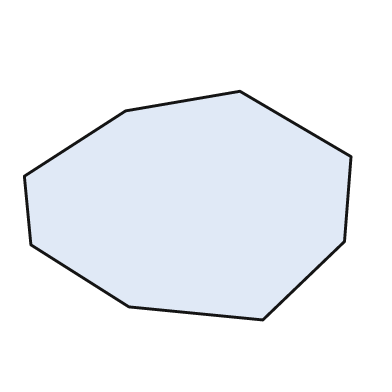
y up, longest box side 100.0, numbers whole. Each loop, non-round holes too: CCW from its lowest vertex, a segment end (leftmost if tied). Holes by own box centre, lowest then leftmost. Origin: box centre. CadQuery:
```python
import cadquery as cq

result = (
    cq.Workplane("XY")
    .moveTo(23.0, -35.0)
    .lineTo(48.0, -11.0)
    .lineTo(50.0, 15.0)
    .lineTo(16.0, 35.0)
    .lineTo(-19.0, 29.0)
    .lineTo(-50.0, 9.0)
    .lineTo(-48.0, -12.0)
    .lineTo(-18.0, -31.0)
    .close()
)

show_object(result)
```